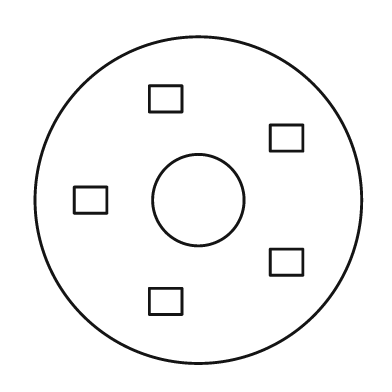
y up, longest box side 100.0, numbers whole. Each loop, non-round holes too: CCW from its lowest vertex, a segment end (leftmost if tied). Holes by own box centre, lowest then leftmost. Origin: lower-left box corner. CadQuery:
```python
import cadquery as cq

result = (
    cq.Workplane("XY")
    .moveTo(50.0, 50.0)
    .circle(50.0)
    .moveTo(35.0, 15.0)
    .lineTo(45.0, 15.0)
    .lineTo(45.0, 23.0)
    .lineTo(35.0, 23.0)
    .close()
    .moveTo(72.0, 27.0)
    .lineTo(82.0, 27.0)
    .lineTo(82.0, 35.0)
    .lineTo(72.0, 35.0)
    .close()
    .moveTo(12.0, 46.0)
    .lineTo(22.0, 46.0)
    .lineTo(22.0, 54.0)
    .lineTo(12.0, 54.0)
    .close()
    .moveTo(50.0, 50.0)
    .circle(14.0)
    .moveTo(72.0, 65.0)
    .lineTo(82.0, 65.0)
    .lineTo(82.0, 73.0)
    .lineTo(72.0, 73.0)
    .close()
    .moveTo(35.0, 77.0)
    .lineTo(45.0, 77.0)
    .lineTo(45.0, 85.0)
    .lineTo(35.0, 85.0)
    .close()
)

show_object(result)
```